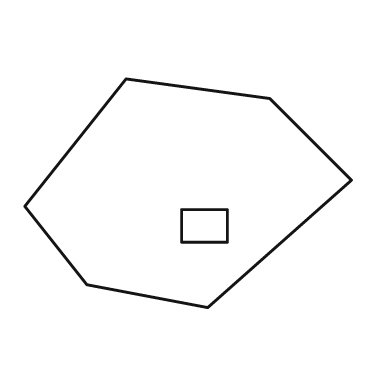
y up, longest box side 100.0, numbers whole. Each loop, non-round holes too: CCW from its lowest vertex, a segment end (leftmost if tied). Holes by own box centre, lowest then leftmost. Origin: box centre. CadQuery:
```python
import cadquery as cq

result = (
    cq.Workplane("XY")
    .moveTo(6.0, -35.0)
    .lineTo(50.0, 4.0)
    .lineTo(25.0, 29.0)
    .lineTo(-19.0, 35.0)
    .lineTo(-50.0, -4.0)
    .lineTo(-31.0, -28.0)
    .close()
    .moveTo(-2.0, -15.0)
    .lineTo(12.0, -15.0)
    .lineTo(12.0, -5.0)
    .lineTo(-2.0, -5.0)
    .close()
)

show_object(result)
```